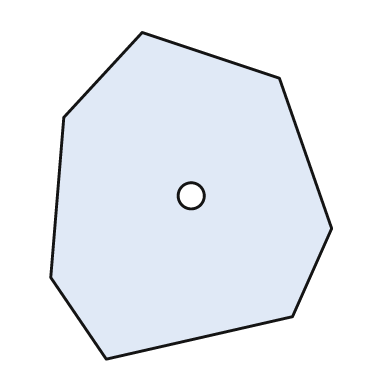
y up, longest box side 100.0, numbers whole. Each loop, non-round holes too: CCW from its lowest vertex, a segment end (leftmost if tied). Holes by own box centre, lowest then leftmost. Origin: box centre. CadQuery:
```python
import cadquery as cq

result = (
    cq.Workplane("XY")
    .moveTo(-26.0, -50.0)
    .lineTo(31.0, -37.0)
    .lineTo(43.0, -10.0)
    .lineTo(27.0, 36.0)
    .lineTo(-15.0, 50.0)
    .lineTo(-39.0, 24.0)
    .lineTo(-43.0, -25.0)
    .close()
    .moveTo(0.0, 0.0)
    .circle(4.0)
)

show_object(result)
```